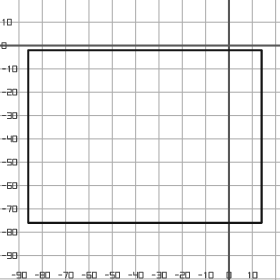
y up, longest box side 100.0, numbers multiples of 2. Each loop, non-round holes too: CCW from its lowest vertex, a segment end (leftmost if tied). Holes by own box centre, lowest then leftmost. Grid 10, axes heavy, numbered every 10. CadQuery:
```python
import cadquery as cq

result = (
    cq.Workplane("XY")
    .moveTo(-86.0, -76.0)
    .lineTo(14.0, -76.0)
    .lineTo(14.0, -2.0)
    .lineTo(-86.0, -2.0)
    .close()
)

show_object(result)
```